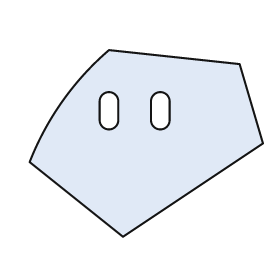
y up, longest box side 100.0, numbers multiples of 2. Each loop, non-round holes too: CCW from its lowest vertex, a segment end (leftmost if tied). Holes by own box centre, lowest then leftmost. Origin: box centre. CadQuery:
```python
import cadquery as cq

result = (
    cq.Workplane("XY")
    .moveTo(-10.0, -40.0)
    .lineTo(50.0, 0.0)
    .lineTo(40.0, 34.0)
    .lineTo(-16.0, 40.0)
    .threePointArc((-36.0, 18.0), (-50.0, -8.0))
    .close()
    .moveTo(-20.0, 10.0)
    .threePointArc((-16.0, 6.0), (-12.0, 10.0))
    .lineTo(-12.0, 18.0)
    .threePointArc((-16.0, 22.0), (-20.0, 18.0))
    .close()
    .moveTo(2.0, 10.0)
    .threePointArc((6.0, 6.0), (10.0, 10.0))
    .lineTo(10.0, 18.0)
    .threePointArc((6.0, 22.0), (2.0, 18.0))
    .close()
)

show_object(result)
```